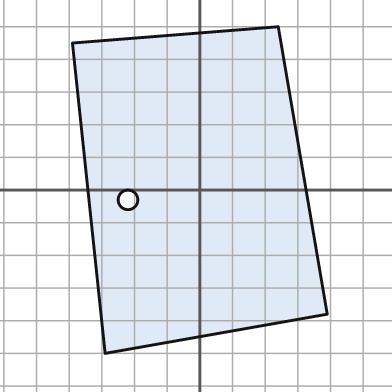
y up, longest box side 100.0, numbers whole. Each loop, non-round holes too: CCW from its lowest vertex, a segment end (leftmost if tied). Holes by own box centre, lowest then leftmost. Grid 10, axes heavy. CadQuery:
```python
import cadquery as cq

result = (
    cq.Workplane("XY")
    .moveTo(-29.0, -50.0)
    .lineTo(39.0, -38.0)
    .lineTo(24.0, 50.0)
    .lineTo(-39.0, 45.0)
    .close()
    .moveTo(-22.0, -3.0)
    .circle(3.0)
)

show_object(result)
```